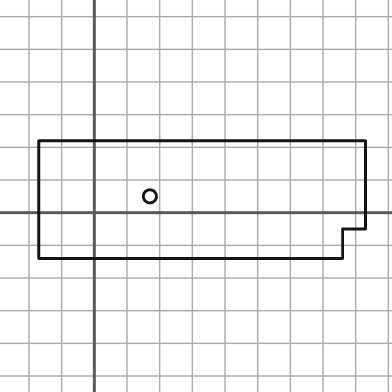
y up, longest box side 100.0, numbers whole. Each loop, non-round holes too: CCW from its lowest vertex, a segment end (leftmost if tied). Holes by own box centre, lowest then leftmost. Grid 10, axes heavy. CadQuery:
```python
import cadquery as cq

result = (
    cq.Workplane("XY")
    .moveTo(-17.0, -14.0)
    .lineTo(76.0, -14.0)
    .lineTo(76.0, -5.0)
    .lineTo(83.0, -5.0)
    .lineTo(83.0, 22.0)
    .lineTo(-17.0, 22.0)
    .close()
    .moveTo(17.0, 5.0)
    .circle(2.0)
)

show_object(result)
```